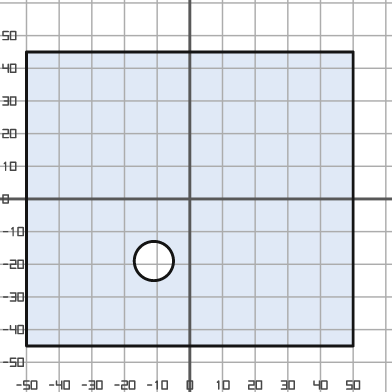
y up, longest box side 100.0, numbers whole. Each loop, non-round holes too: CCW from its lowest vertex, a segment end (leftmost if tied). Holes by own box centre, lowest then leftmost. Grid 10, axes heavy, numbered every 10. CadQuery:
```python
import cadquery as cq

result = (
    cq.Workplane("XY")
    .moveTo(-50.0, -45.0)
    .lineTo(50.0, -45.0)
    .lineTo(50.0, 45.0)
    .lineTo(-50.0, 45.0)
    .close()
    .moveTo(-11.0, -19.0)
    .circle(6.0)
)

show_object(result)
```